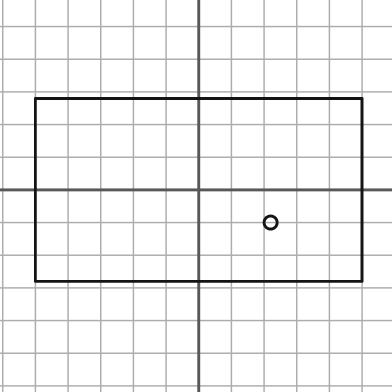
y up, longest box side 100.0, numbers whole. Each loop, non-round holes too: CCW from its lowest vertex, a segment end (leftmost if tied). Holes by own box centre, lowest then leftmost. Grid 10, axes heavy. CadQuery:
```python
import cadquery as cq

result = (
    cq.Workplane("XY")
    .moveTo(-50.0, -28.0)
    .lineTo(50.0, -28.0)
    .lineTo(50.0, 28.0)
    .lineTo(-50.0, 28.0)
    .close()
    .moveTo(22.0, -10.0)
    .circle(2.0)
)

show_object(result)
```